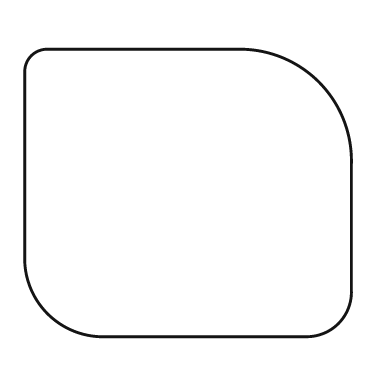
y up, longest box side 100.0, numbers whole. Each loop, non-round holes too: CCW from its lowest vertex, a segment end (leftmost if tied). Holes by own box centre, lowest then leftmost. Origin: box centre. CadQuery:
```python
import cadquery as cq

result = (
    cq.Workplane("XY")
    .moveTo(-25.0, -44.0)
    .lineTo(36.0, -44.0)
    .threePointArc((46.0, -40.0), (50.0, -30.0))
    .lineTo(50.0, 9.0)
    .threePointArc((40.0, 34.0), (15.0, 44.0))
    .lineTo(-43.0, 44.0)
    .threePointArc((-48.0, 42.0), (-50.0, 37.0))
    .lineTo(-50.0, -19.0)
    .threePointArc((-43.0, -37.0), (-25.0, -44.0))
    .close()
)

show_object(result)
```